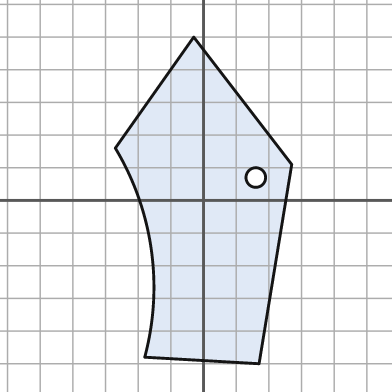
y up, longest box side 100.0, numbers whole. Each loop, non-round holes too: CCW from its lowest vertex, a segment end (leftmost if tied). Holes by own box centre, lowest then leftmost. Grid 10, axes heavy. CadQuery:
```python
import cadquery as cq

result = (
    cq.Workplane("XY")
    .moveTo(17.0, -50.0)
    .lineTo(27.0, 11.0)
    .lineTo(-3.0, 50.0)
    .lineTo(-27.0, 16.0)
    .threePointArc((-16.0, -15.0), (-18.0, -48.0))
    .close()
    .moveTo(16.0, 7.0)
    .circle(3.0)
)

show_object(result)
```